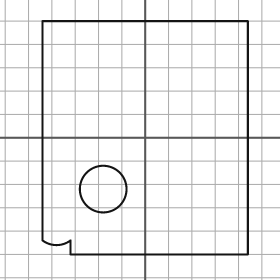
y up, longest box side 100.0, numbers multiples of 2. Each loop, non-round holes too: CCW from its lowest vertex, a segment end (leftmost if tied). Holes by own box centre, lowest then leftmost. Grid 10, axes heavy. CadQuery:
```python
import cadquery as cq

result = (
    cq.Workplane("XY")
    .moveTo(-32.0, -50.0)
    .lineTo(44.0, -50.0)
    .lineTo(44.0, 50.0)
    .lineTo(-44.0, 50.0)
    .lineTo(-44.0, -44.0)
    .threePointArc((-38.0, -46.0), (-32.0, -44.0))
    .close()
    .moveTo(-18.0, -22.0)
    .circle(10.0)
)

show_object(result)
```